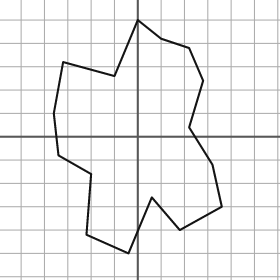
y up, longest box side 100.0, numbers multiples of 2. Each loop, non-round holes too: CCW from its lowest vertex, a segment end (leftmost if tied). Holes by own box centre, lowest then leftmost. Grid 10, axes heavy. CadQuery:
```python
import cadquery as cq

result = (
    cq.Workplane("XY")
    .moveTo(-4.0, -50.0)
    .lineTo(6.0, -26.0)
    .lineTo(18.0, -40.0)
    .lineTo(36.0, -30.0)
    .lineTo(32.0, -12.0)
    .lineTo(22.0, 4.0)
    .lineTo(28.0, 24.0)
    .lineTo(22.0, 38.0)
    .lineTo(10.0, 42.0)
    .lineTo(0.0, 50.0)
    .lineTo(-10.0, 26.0)
    .lineTo(-32.0, 32.0)
    .lineTo(-36.0, 10.0)
    .lineTo(-34.0, -8.0)
    .lineTo(-20.0, -16.0)
    .lineTo(-22.0, -42.0)
    .close()
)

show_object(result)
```